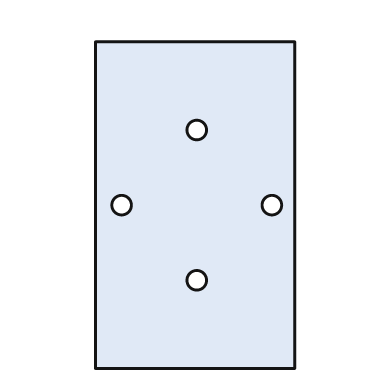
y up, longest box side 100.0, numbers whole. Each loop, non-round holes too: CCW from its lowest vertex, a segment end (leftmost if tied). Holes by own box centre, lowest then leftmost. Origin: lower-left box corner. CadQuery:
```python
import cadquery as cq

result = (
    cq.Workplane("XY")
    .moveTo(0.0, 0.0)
    .lineTo(61.0, 0.0)
    .lineTo(61.0, 100.0)
    .lineTo(0.0, 100.0)
    .close()
    .moveTo(31.0, 27.0)
    .circle(3.0)
    .moveTo(8.0, 50.0)
    .circle(3.0)
    .moveTo(54.0, 50.0)
    .circle(3.0)
    .moveTo(31.0, 73.0)
    .circle(3.0)
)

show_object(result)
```